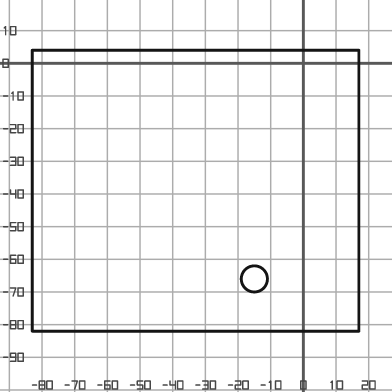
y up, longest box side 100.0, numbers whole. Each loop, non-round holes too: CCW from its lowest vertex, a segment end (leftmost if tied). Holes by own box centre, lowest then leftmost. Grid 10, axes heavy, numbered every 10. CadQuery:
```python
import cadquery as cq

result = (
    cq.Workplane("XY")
    .moveTo(-83.0, -82.0)
    .lineTo(17.0, -82.0)
    .lineTo(17.0, 4.0)
    .lineTo(-83.0, 4.0)
    .close()
    .moveTo(-15.0, -66.0)
    .circle(4.0)
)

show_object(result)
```